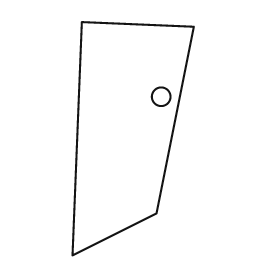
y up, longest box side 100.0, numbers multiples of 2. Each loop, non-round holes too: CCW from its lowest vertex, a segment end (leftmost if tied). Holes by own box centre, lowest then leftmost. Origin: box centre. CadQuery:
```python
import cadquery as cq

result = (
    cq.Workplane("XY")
    .moveTo(-26.0, -50.0)
    .lineTo(10.0, -32.0)
    .lineTo(26.0, 48.0)
    .lineTo(-22.0, 50.0)
    .close()
    .moveTo(12.0, 18.0)
    .circle(4.0)
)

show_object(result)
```